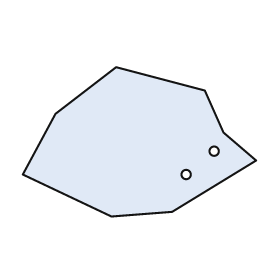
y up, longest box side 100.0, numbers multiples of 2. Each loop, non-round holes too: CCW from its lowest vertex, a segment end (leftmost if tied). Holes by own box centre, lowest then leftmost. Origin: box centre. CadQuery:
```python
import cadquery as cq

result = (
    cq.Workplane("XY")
    .moveTo(-12.0, -32.0)
    .lineTo(14.0, -30.0)
    .lineTo(50.0, -8.0)
    .lineTo(36.0, 4.0)
    .lineTo(28.0, 22.0)
    .lineTo(-10.0, 32.0)
    .lineTo(-36.0, 12.0)
    .lineTo(-50.0, -14.0)
    .close()
    .moveTo(20.0, -14.0)
    .circle(2.0)
    .moveTo(32.0, -4.0)
    .circle(2.0)
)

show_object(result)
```